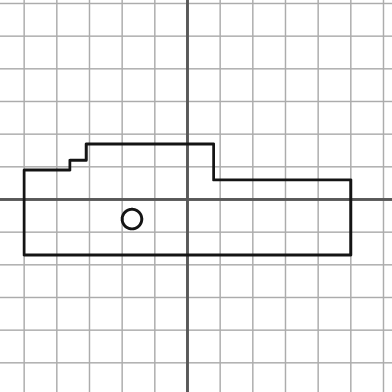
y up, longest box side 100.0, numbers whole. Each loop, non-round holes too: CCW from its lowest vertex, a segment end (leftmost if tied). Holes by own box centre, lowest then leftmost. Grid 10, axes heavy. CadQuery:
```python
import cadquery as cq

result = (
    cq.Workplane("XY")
    .moveTo(-50.0, -17.0)
    .lineTo(50.0, -17.0)
    .lineTo(50.0, 6.0)
    .lineTo(8.0, 6.0)
    .lineTo(8.0, 17.0)
    .lineTo(-31.0, 17.0)
    .lineTo(-31.0, 12.0)
    .lineTo(-36.0, 12.0)
    .lineTo(-36.0, 9.0)
    .lineTo(-50.0, 9.0)
    .close()
    .moveTo(-17.0, -6.0)
    .circle(3.0)
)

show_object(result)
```